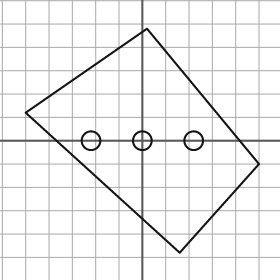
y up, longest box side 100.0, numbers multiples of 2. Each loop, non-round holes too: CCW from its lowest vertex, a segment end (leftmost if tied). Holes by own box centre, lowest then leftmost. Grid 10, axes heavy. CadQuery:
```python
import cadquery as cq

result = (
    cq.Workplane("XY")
    .moveTo(16.0, -48.0)
    .lineTo(50.0, -10.0)
    .lineTo(2.0, 48.0)
    .lineTo(-50.0, 12.0)
    .close()
    .moveTo(-22.0, 0.0)
    .circle(4.0)
    .moveTo(0.0, 0.0)
    .circle(4.0)
    .moveTo(22.0, 0.0)
    .circle(4.0)
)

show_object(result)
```